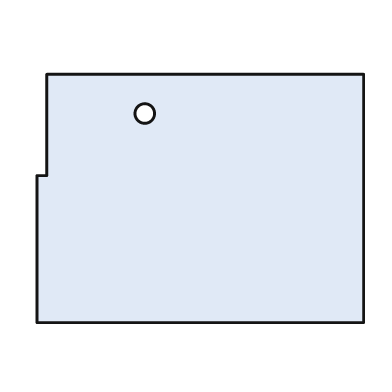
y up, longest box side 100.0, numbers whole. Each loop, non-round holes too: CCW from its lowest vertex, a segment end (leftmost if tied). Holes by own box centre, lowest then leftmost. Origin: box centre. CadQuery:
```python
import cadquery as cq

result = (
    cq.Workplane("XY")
    .moveTo(-50.0, -38.0)
    .lineTo(50.0, -38.0)
    .lineTo(50.0, 38.0)
    .lineTo(-47.0, 38.0)
    .lineTo(-47.0, 7.0)
    .lineTo(-50.0, 7.0)
    .close()
    .moveTo(-17.0, 26.0)
    .circle(3.0)
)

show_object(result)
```